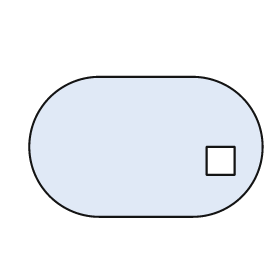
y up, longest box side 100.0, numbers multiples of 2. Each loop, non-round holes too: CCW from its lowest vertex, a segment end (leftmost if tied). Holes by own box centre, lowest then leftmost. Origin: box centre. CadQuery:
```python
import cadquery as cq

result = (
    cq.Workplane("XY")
    .moveTo(-20.0, -30.0)
    .lineTo(20.0, -30.0)
    .threePointArc((50.0, 0.0), (20.0, 30.0))
    .lineTo(-20.0, 30.0)
    .threePointArc((-50.0, 0.0), (-20.0, -30.0))
    .close()
    .moveTo(26.0, -12.0)
    .lineTo(38.0, -12.0)
    .lineTo(38.0, 0.0)
    .lineTo(26.0, 0.0)
    .close()
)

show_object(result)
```